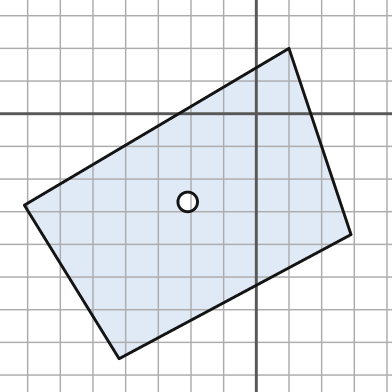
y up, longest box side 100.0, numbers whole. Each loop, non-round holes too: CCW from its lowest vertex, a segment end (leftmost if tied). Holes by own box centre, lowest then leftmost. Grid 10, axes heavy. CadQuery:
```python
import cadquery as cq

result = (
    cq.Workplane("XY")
    .moveTo(-42.0, -75.0)
    .lineTo(29.0, -37.0)
    .lineTo(10.0, 20.0)
    .lineTo(-71.0, -28.0)
    .close()
    .moveTo(-21.0, -27.0)
    .circle(3.0)
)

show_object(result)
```